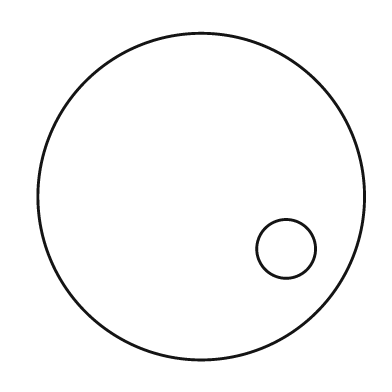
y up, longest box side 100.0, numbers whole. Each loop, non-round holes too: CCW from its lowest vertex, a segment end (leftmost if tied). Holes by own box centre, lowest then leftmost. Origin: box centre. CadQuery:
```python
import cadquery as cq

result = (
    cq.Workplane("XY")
    .moveTo(0.0, 0.0)
    .circle(50.0)
    .moveTo(26.0, -16.0)
    .circle(9.0)
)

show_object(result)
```